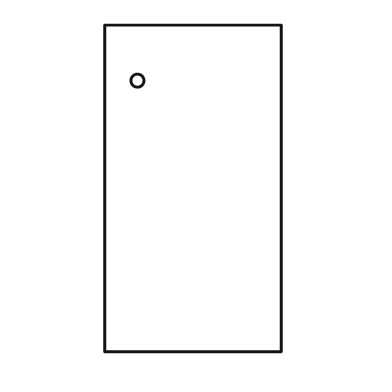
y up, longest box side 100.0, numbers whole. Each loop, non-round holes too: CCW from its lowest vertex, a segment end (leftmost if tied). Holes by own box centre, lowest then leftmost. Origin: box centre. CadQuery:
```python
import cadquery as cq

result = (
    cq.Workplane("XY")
    .moveTo(-27.0, -50.0)
    .lineTo(27.0, -50.0)
    .lineTo(27.0, 50.0)
    .lineTo(-27.0, 50.0)
    .close()
    .moveTo(-17.0, 33.0)
    .circle(2.0)
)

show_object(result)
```